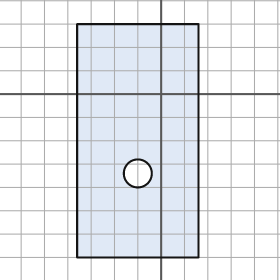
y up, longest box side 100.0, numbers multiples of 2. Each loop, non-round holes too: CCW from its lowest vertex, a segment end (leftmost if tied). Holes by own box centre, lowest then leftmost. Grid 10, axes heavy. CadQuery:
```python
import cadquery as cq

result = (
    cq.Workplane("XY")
    .moveTo(-36.0, -70.0)
    .lineTo(16.0, -70.0)
    .lineTo(16.0, 30.0)
    .lineTo(-36.0, 30.0)
    .close()
    .moveTo(-10.0, -34.0)
    .circle(6.0)
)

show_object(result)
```